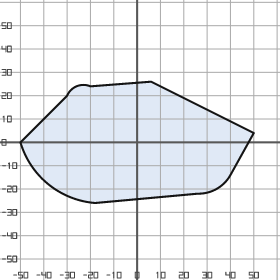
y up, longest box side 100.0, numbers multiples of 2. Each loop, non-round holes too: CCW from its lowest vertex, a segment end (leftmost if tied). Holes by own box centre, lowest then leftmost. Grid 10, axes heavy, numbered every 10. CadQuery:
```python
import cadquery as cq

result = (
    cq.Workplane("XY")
    .moveTo(-18.0, -26.0)
    .lineTo(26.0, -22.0)
    .threePointArc((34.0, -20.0), (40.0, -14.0))
    .lineTo(50.0, 4.0)
    .lineTo(6.0, 26.0)
    .lineTo(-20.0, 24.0)
    .threePointArc((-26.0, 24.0), (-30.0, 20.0))
    .lineTo(-50.0, 0.0)
    .threePointArc((-38.0, -18.0), (-18.0, -26.0))
    .close()
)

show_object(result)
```